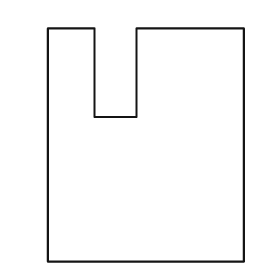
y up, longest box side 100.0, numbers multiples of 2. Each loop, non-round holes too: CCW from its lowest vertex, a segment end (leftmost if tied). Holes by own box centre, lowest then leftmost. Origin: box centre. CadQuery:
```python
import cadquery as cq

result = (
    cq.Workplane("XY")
    .moveTo(-42.0, -50.0)
    .lineTo(42.0, -50.0)
    .lineTo(42.0, 50.0)
    .lineTo(-4.0, 50.0)
    .lineTo(-4.0, 12.0)
    .lineTo(-22.0, 12.0)
    .lineTo(-22.0, 50.0)
    .lineTo(-42.0, 50.0)
    .close()
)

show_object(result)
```